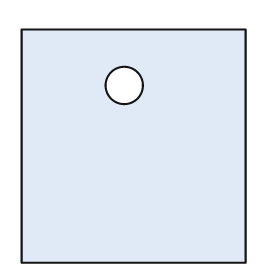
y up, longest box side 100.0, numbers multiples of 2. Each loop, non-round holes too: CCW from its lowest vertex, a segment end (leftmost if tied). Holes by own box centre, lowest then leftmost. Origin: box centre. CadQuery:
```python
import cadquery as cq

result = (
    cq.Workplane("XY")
    .moveTo(-48.0, -50.0)
    .lineTo(48.0, -50.0)
    .lineTo(48.0, 50.0)
    .lineTo(-48.0, 50.0)
    .close()
    .moveTo(-4.0, 26.0)
    .circle(8.0)
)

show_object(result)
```